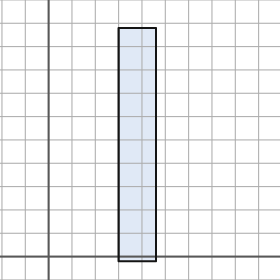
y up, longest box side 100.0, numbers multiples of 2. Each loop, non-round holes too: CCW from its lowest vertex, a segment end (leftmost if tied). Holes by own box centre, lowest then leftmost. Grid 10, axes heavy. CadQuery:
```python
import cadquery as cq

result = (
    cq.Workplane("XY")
    .moveTo(30.0, -2.0)
    .lineTo(46.0, -2.0)
    .lineTo(46.0, 98.0)
    .lineTo(30.0, 98.0)
    .close()
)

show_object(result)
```